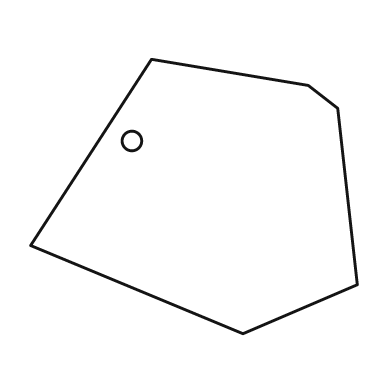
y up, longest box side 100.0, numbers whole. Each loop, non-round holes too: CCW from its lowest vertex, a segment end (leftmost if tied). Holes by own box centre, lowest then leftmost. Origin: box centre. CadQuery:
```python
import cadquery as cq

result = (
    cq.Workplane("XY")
    .moveTo(15.0, -42.0)
    .lineTo(50.0, -27.0)
    .lineTo(44.0, 27.0)
    .lineTo(35.0, 34.0)
    .lineTo(-13.0, 42.0)
    .lineTo(-50.0, -15.0)
    .close()
    .moveTo(-19.0, 17.0)
    .circle(3.0)
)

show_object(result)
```